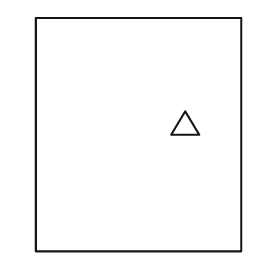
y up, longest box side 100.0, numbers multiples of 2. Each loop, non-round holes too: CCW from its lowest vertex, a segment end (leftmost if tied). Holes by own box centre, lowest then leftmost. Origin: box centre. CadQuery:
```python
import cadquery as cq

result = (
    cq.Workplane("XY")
    .moveTo(-44.0, -50.0)
    .lineTo(44.0, -50.0)
    .lineTo(44.0, 50.0)
    .lineTo(-44.0, 50.0)
    .close()
    .moveTo(14.0, 0.0)
    .lineTo(26.0, 0.0)
    .lineTo(20.0, 10.0)
    .close()
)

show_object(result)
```